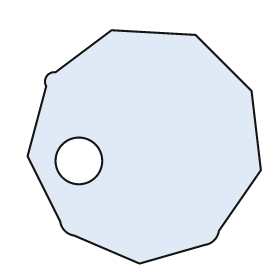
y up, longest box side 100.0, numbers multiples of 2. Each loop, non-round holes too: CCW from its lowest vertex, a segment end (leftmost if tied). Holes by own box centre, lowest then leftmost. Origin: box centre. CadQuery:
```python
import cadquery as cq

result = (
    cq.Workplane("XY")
    .moveTo(-2.0, -50.0)
    .lineTo(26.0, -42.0)
    .threePointArc((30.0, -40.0), (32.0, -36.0))
    .lineTo(50.0, -10.0)
    .lineTo(46.0, 24.0)
    .lineTo(22.0, 48.0)
    .lineTo(-14.0, 50.0)
    .lineTo(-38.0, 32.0)
    .threePointArc((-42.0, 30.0), (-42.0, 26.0))
    .lineTo(-50.0, -4.0)
    .lineTo(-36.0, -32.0)
    .threePointArc((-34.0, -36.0), (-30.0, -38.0))
    .close()
    .moveTo(-28.0, -6.0)
    .circle(10.0)
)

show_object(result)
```